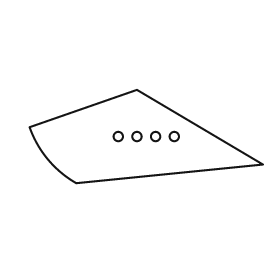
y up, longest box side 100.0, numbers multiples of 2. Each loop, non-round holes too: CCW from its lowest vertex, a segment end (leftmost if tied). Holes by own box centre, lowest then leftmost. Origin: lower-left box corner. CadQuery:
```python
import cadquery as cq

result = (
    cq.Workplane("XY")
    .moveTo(20.0, 0.0)
    .lineTo(100.0, 8.0)
    .lineTo(46.0, 40.0)
    .lineTo(0.0, 24.0)
    .threePointArc((8.0, 10.0), (20.0, 0.0))
    .close()
    .moveTo(38.0, 20.0)
    .circle(2.0)
    .moveTo(46.0, 20.0)
    .circle(2.0)
    .moveTo(54.0, 20.0)
    .circle(2.0)
    .moveTo(62.0, 20.0)
    .circle(2.0)
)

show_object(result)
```